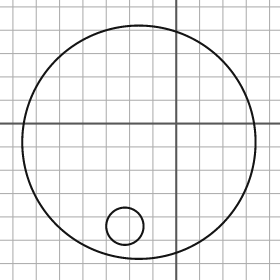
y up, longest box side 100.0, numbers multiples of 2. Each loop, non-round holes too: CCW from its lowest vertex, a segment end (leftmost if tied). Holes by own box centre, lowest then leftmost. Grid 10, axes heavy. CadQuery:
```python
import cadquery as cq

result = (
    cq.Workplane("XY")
    .moveTo(-16.0, -8.0)
    .circle(50.0)
    .moveTo(-22.0, -44.0)
    .circle(8.0)
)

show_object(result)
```